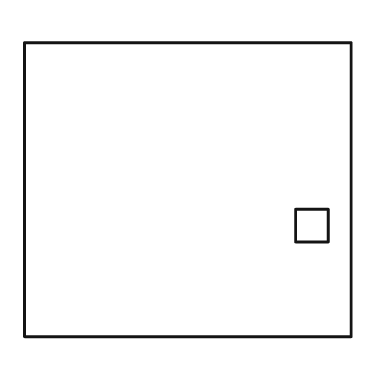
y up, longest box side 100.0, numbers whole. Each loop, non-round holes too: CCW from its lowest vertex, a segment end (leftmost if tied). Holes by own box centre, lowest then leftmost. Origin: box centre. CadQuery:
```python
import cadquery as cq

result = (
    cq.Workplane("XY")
    .moveTo(-50.0, -45.0)
    .lineTo(50.0, -45.0)
    .lineTo(50.0, 45.0)
    .lineTo(-50.0, 45.0)
    .close()
    .moveTo(33.0, -16.0)
    .lineTo(43.0, -16.0)
    .lineTo(43.0, -6.0)
    .lineTo(33.0, -6.0)
    .close()
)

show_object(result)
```